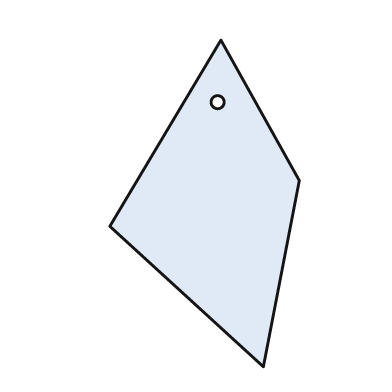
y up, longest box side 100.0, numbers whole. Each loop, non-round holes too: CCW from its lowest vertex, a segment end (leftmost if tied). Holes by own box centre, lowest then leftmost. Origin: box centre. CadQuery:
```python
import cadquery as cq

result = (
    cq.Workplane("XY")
    .moveTo(18.0, -50.0)
    .lineTo(29.0, 7.0)
    .lineTo(5.0, 50.0)
    .lineTo(-29.0, -7.0)
    .close()
    .moveTo(4.0, 31.0)
    .circle(2.0)
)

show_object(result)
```